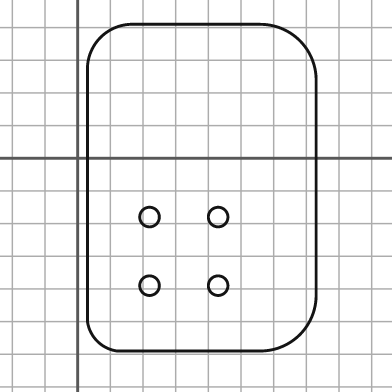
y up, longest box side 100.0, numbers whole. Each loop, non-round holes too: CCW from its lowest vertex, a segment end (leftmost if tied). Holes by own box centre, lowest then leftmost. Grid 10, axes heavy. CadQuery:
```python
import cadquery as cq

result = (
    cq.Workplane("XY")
    .moveTo(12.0, -59.0)
    .lineTo(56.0, -59.0)
    .threePointArc((68.0, -54.0), (73.0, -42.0))
    .lineTo(73.0, 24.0)
    .threePointArc((68.0, 36.0), (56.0, 41.0))
    .lineTo(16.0, 41.0)
    .threePointArc((7.0, 37.0), (3.0, 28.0))
    .lineTo(3.0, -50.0)
    .threePointArc((6.0, -56.0), (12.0, -59.0))
    .close()
    .moveTo(22.0, -39.0)
    .circle(3.0)
    .moveTo(43.0, -39.0)
    .circle(3.0)
    .moveTo(22.0, -18.0)
    .circle(3.0)
    .moveTo(43.0, -18.0)
    .circle(3.0)
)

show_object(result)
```